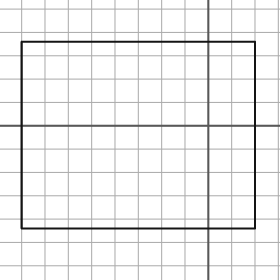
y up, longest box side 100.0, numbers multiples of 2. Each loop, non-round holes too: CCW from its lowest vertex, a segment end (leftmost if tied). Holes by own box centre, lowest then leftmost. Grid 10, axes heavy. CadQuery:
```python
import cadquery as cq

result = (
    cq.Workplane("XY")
    .moveTo(-80.0, -44.0)
    .lineTo(20.0, -44.0)
    .lineTo(20.0, 36.0)
    .lineTo(-80.0, 36.0)
    .close()
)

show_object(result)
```